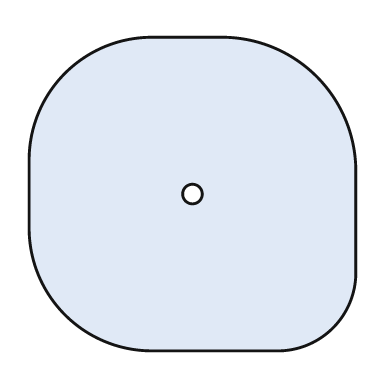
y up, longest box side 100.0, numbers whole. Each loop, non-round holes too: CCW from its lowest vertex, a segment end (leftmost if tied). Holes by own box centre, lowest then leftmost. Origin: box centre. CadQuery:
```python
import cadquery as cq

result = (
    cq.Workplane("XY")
    .moveTo(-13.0, -48.0)
    .lineTo(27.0, -48.0)
    .threePointArc((43.0, -41.0), (50.0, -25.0))
    .lineTo(50.0, 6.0)
    .threePointArc((38.0, 36.0), (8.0, 48.0))
    .lineTo(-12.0, 48.0)
    .threePointArc((-39.0, 37.0), (-50.0, 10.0))
    .lineTo(-50.0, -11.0)
    .threePointArc((-39.0, -37.0), (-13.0, -48.0))
    .close()
    .moveTo(0.0, 0.0)
    .circle(3.0)
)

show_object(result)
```